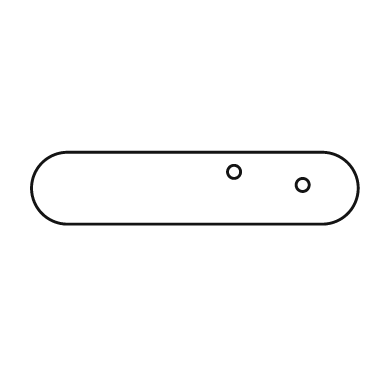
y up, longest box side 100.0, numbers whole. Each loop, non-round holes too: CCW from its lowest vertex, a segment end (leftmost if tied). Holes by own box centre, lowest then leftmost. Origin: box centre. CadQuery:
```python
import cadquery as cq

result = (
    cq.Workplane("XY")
    .moveTo(-39.0, -11.0)
    .lineTo(39.0, -11.0)
    .threePointArc((50.0, 0.0), (39.0, 11.0))
    .lineTo(-39.0, 11.0)
    .threePointArc((-50.0, 0.0), (-39.0, -11.0))
    .close()
    .moveTo(33.0, 1.0)
    .circle(2.0)
    .moveTo(12.0, 5.0)
    .circle(2.0)
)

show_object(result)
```